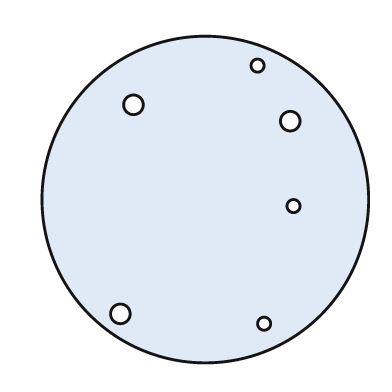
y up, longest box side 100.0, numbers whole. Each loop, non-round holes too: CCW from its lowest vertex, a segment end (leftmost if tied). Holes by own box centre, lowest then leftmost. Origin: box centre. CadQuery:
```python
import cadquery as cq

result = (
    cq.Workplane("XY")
    .moveTo(0.0, 0.0)
    .circle(50.0)
    .moveTo(18.0, -38.0)
    .circle(2.0)
    .moveTo(-26.0, -35.0)
    .circle(3.0)
    .moveTo(27.0, -2.0)
    .circle(2.0)
    .moveTo(26.0, 24.0)
    .circle(3.0)
    .moveTo(-22.0, 29.0)
    .circle(3.0)
    .moveTo(16.0, 41.0)
    .circle(2.0)
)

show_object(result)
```